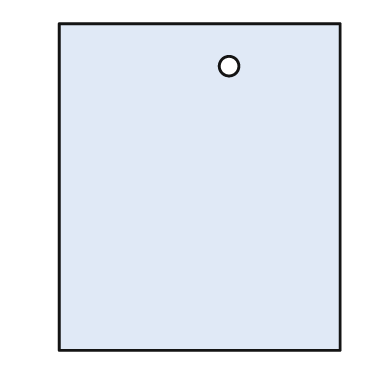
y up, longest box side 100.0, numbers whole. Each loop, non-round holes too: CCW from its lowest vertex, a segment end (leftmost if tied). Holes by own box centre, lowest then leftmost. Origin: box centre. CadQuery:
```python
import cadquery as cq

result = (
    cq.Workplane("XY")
    .moveTo(-43.0, -50.0)
    .lineTo(43.0, -50.0)
    .lineTo(43.0, 50.0)
    .lineTo(-43.0, 50.0)
    .close()
    .moveTo(9.0, 37.0)
    .circle(3.0)
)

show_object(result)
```